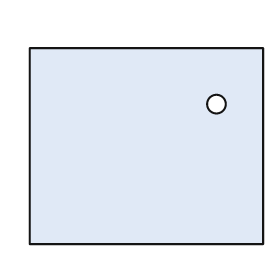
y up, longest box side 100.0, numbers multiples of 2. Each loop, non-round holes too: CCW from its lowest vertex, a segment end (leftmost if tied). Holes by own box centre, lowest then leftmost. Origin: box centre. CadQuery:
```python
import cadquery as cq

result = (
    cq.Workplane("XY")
    .moveTo(-50.0, -42.0)
    .lineTo(50.0, -42.0)
    .lineTo(50.0, 42.0)
    .lineTo(-50.0, 42.0)
    .close()
    .moveTo(30.0, 18.0)
    .circle(4.0)
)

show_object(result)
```